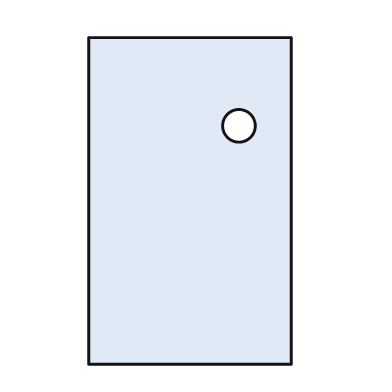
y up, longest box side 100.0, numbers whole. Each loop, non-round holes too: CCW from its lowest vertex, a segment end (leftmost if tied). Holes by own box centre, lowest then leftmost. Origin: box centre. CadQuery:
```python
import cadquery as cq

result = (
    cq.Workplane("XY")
    .moveTo(-31.0, -50.0)
    .lineTo(31.0, -50.0)
    .lineTo(31.0, 50.0)
    .lineTo(-31.0, 50.0)
    .close()
    .moveTo(15.0, 23.0)
    .circle(5.0)
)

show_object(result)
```